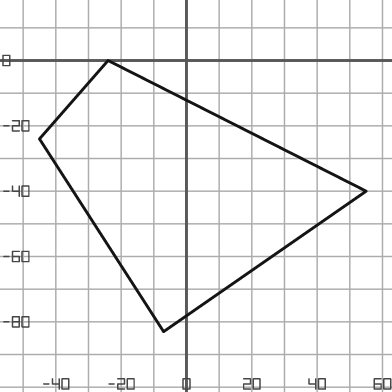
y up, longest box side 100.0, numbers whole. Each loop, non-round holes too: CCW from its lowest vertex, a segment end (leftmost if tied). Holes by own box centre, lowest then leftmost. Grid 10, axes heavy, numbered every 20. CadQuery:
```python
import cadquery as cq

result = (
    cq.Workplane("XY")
    .moveTo(-7.0, -83.0)
    .lineTo(55.0, -40.0)
    .lineTo(-24.0, 0.0)
    .lineTo(-45.0, -24.0)
    .close()
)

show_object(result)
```